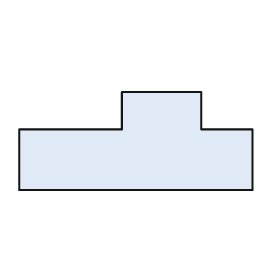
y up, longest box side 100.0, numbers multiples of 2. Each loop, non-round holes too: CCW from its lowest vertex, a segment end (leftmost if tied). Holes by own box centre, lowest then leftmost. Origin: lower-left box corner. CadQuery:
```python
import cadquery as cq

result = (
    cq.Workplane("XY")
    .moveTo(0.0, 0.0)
    .lineTo(100.0, 0.0)
    .lineTo(100.0, 26.0)
    .lineTo(78.0, 26.0)
    .lineTo(78.0, 42.0)
    .lineTo(44.0, 42.0)
    .lineTo(44.0, 26.0)
    .lineTo(0.0, 26.0)
    .close()
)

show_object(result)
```